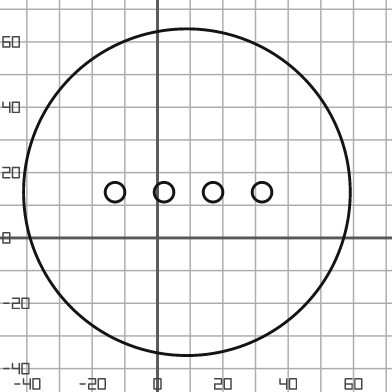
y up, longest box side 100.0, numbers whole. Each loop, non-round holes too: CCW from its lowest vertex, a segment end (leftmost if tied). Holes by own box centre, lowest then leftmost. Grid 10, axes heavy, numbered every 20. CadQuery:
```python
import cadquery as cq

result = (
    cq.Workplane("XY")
    .moveTo(9.0, 14.0)
    .circle(50.0)
    .moveTo(-13.0, 14.0)
    .circle(3.0)
    .moveTo(2.0, 14.0)
    .circle(3.0)
    .moveTo(17.0, 14.0)
    .circle(3.0)
    .moveTo(32.0, 14.0)
    .circle(3.0)
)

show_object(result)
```